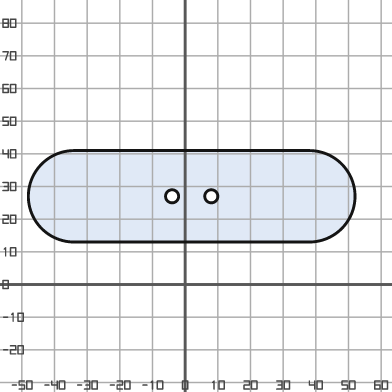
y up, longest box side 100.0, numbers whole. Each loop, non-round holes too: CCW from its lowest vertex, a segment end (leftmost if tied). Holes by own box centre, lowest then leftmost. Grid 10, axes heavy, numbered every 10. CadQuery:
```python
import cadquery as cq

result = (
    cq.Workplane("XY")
    .moveTo(-34.0, 13.0)
    .lineTo(38.0, 13.0)
    .threePointArc((52.0, 27.0), (38.0, 41.0))
    .lineTo(-34.0, 41.0)
    .threePointArc((-48.0, 27.0), (-34.0, 13.0))
    .close()
    .moveTo(-4.0, 27.0)
    .circle(2.0)
    .moveTo(8.0, 27.0)
    .circle(2.0)
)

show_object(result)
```